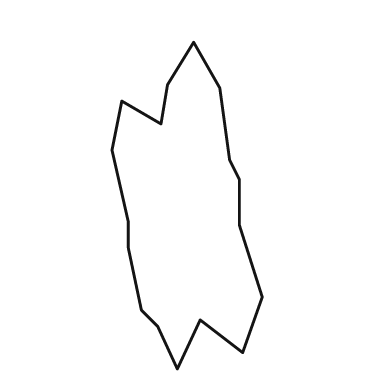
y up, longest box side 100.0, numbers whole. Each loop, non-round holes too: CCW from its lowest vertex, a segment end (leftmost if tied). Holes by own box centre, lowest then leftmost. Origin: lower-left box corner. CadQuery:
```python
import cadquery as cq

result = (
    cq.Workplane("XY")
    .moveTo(20.0, 0.0)
    .lineTo(27.0, 15.0)
    .lineTo(40.0, 5.0)
    .lineTo(46.0, 22.0)
    .lineTo(39.0, 44.0)
    .lineTo(39.0, 58.0)
    .lineTo(36.0, 64.0)
    .lineTo(33.0, 86.0)
    .lineTo(25.0, 100.0)
    .lineTo(17.0, 87.0)
    .lineTo(15.0, 75.0)
    .lineTo(3.0, 82.0)
    .lineTo(0.0, 67.0)
    .lineTo(5.0, 45.0)
    .lineTo(5.0, 37.0)
    .lineTo(9.0, 18.0)
    .lineTo(14.0, 13.0)
    .close()
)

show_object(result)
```